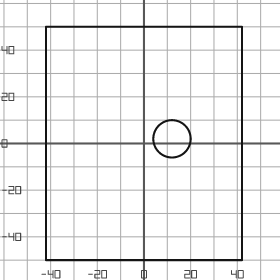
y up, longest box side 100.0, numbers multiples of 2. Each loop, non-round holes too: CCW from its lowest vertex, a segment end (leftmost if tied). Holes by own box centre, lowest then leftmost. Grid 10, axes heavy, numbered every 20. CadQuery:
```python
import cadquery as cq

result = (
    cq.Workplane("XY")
    .moveTo(-42.0, -50.0)
    .lineTo(42.0, -50.0)
    .lineTo(42.0, 50.0)
    .lineTo(-42.0, 50.0)
    .close()
    .moveTo(12.0, 2.0)
    .circle(8.0)
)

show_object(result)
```